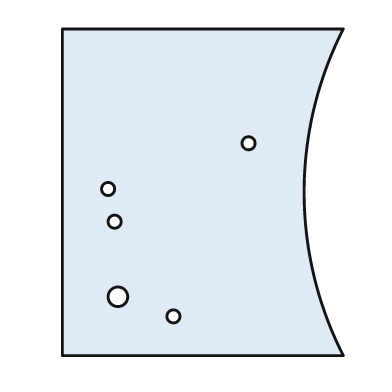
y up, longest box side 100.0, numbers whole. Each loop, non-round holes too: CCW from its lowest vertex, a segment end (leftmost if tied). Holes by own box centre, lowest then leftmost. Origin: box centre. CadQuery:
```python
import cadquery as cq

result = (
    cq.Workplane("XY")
    .moveTo(-43.0, -50.0)
    .lineTo(43.0, -50.0)
    .threePointArc((31.0, 0.0), (43.0, 50.0))
    .lineTo(-43.0, 50.0)
    .close()
    .moveTo(-9.0, -38.0)
    .circle(2.0)
    .moveTo(-26.0, -32.0)
    .circle(3.0)
    .moveTo(-27.0, -9.0)
    .circle(2.0)
    .moveTo(-29.0, 1.0)
    .circle(2.0)
    .moveTo(14.0, 15.0)
    .circle(2.0)
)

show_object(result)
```